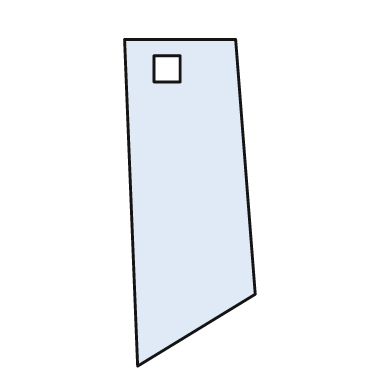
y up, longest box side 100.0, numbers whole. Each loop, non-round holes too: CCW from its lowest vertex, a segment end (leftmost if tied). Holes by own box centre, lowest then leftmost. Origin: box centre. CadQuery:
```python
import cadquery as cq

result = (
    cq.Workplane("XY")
    .moveTo(-16.0, -50.0)
    .lineTo(20.0, -28.0)
    .lineTo(14.0, 50.0)
    .lineTo(-20.0, 50.0)
    .close()
    .moveTo(-11.0, 37.0)
    .lineTo(-3.0, 37.0)
    .lineTo(-3.0, 45.0)
    .lineTo(-11.0, 45.0)
    .close()
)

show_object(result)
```